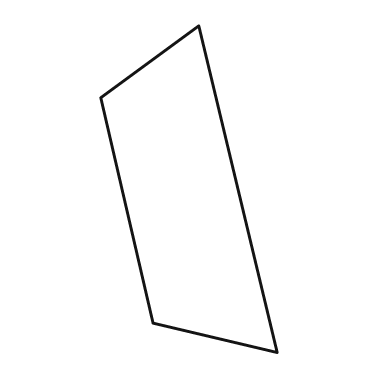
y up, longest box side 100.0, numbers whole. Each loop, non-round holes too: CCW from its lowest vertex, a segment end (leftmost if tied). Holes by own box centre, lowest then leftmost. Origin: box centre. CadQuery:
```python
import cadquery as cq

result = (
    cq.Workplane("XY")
    .moveTo(27.0, -50.0)
    .lineTo(3.0, 50.0)
    .lineTo(-27.0, 28.0)
    .lineTo(-11.0, -41.0)
    .close()
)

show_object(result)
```